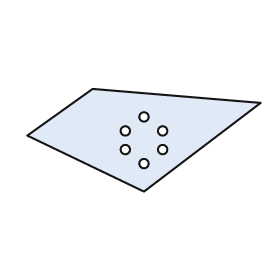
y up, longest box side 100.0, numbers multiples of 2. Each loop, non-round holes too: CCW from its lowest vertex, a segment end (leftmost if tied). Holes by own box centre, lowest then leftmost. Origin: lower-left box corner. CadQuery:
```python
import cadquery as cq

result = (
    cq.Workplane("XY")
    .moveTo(50.0, 0.0)
    .lineTo(100.0, 38.0)
    .lineTo(28.0, 44.0)
    .lineTo(0.0, 24.0)
    .close()
    .moveTo(50.0, 12.0)
    .circle(2.0)
    .moveTo(42.0, 18.0)
    .circle(2.0)
    .moveTo(58.0, 18.0)
    .circle(2.0)
    .moveTo(42.0, 26.0)
    .circle(2.0)
    .moveTo(58.0, 26.0)
    .circle(2.0)
    .moveTo(50.0, 32.0)
    .circle(2.0)
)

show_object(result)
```